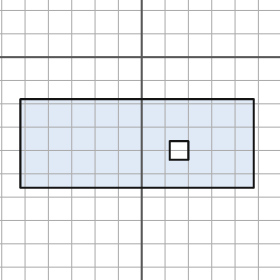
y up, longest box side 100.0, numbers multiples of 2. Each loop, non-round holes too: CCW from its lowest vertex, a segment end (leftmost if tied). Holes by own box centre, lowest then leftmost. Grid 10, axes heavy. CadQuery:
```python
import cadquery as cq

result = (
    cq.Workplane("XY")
    .moveTo(-52.0, -56.0)
    .lineTo(48.0, -56.0)
    .lineTo(48.0, -18.0)
    .lineTo(-52.0, -18.0)
    .close()
    .moveTo(12.0, -44.0)
    .lineTo(20.0, -44.0)
    .lineTo(20.0, -36.0)
    .lineTo(12.0, -36.0)
    .close()
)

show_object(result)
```